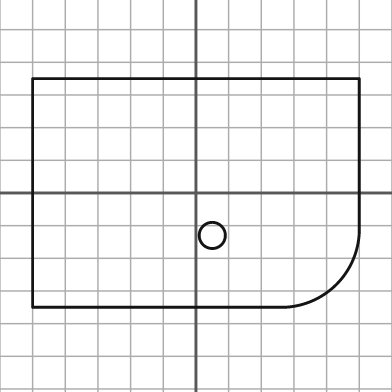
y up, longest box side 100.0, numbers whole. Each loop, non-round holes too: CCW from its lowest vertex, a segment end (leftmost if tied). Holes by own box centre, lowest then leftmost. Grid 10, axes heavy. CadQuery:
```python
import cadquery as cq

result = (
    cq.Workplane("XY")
    .moveTo(-50.0, -35.0)
    .lineTo(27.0, -35.0)
    .threePointArc((43.0, -28.0), (50.0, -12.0))
    .lineTo(50.0, 35.0)
    .lineTo(-50.0, 35.0)
    .close()
    .moveTo(5.0, -13.0)
    .circle(4.0)
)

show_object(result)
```